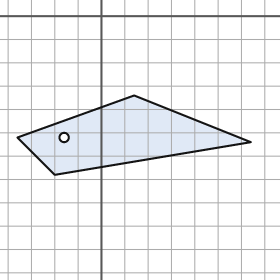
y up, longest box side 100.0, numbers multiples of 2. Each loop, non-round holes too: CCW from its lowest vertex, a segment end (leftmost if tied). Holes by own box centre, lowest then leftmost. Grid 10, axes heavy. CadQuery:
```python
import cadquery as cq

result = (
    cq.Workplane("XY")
    .moveTo(-20.0, -68.0)
    .lineTo(64.0, -54.0)
    .lineTo(14.0, -34.0)
    .lineTo(-36.0, -52.0)
    .close()
    .moveTo(-16.0, -52.0)
    .circle(2.0)
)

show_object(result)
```